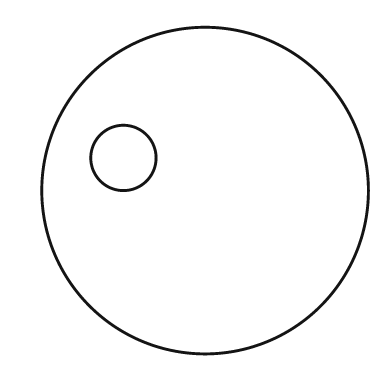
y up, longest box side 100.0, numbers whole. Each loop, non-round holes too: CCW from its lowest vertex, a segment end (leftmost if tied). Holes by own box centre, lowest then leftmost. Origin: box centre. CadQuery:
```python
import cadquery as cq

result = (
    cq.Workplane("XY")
    .moveTo(0.0, 0.0)
    .circle(50.0)
    .moveTo(-25.0, 10.0)
    .circle(10.0)
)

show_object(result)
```